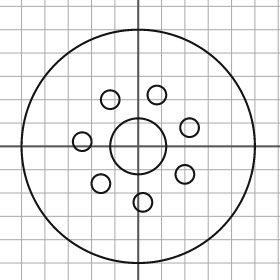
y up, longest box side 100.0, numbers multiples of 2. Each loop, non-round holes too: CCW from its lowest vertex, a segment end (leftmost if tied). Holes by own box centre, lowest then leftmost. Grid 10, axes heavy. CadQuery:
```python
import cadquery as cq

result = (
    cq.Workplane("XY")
    .moveTo(0.0, 0.0)
    .circle(50.0)
    .moveTo(2.0, -24.0)
    .circle(4.0)
    .moveTo(-16.0, -16.0)
    .circle(4.0)
    .moveTo(20.0, -12.0)
    .circle(4.0)
    .moveTo(0.0, 0.0)
    .circle(12.0)
    .moveTo(-24.0, 2.0)
    .circle(4.0)
    .moveTo(22.0, 8.0)
    .circle(4.0)
    .moveTo(-12.0, 20.0)
    .circle(4.0)
    .moveTo(8.0, 22.0)
    .circle(4.0)
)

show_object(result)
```